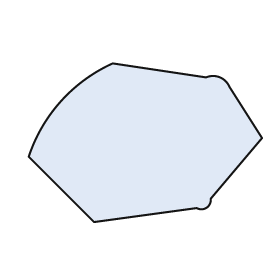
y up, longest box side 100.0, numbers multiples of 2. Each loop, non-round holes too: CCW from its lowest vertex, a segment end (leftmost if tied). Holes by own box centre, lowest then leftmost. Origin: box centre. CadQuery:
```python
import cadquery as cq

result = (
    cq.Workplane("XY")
    .moveTo(-22.0, -34.0)
    .lineTo(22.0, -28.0)
    .threePointArc((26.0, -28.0), (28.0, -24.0))
    .lineTo(50.0, 2.0)
    .lineTo(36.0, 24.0)
    .threePointArc((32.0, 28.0), (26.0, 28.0))
    .lineTo(-14.0, 34.0)
    .threePointArc((-36.0, 18.0), (-50.0, -6.0))
    .close()
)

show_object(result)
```